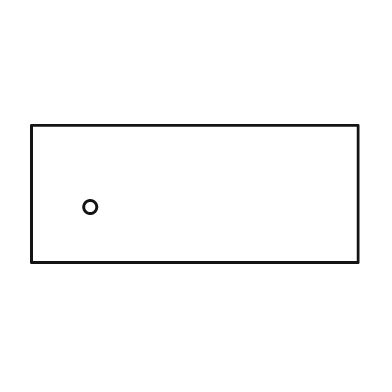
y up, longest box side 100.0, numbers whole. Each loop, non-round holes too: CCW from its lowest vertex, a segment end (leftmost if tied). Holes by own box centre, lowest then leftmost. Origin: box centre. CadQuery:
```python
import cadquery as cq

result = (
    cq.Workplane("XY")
    .moveTo(-50.0, -21.0)
    .lineTo(50.0, -21.0)
    .lineTo(50.0, 21.0)
    .lineTo(-50.0, 21.0)
    .close()
    .moveTo(-32.0, -4.0)
    .circle(2.0)
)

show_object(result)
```